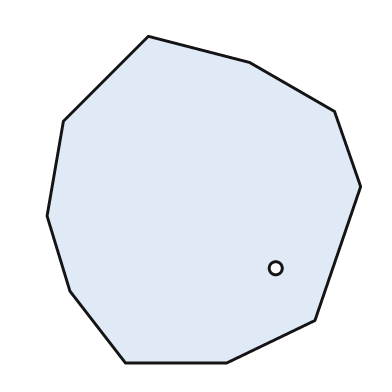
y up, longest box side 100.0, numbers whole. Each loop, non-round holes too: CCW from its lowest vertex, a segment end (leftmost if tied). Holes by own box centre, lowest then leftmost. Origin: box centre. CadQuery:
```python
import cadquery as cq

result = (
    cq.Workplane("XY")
    .moveTo(-24.0, -50.0)
    .lineTo(7.0, -50.0)
    .lineTo(34.0, -37.0)
    .lineTo(48.0, 4.0)
    .lineTo(40.0, 27.0)
    .lineTo(14.0, 42.0)
    .lineTo(-17.0, 50.0)
    .lineTo(-43.0, 24.0)
    .lineTo(-48.0, -5.0)
    .lineTo(-41.0, -28.0)
    .close()
    .moveTo(22.0, -21.0)
    .circle(2.0)
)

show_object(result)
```